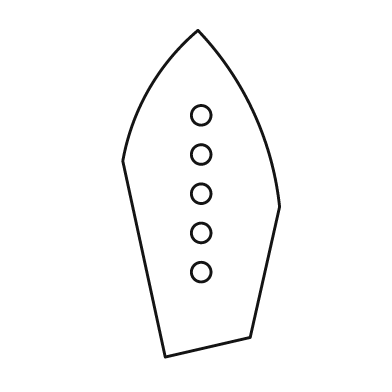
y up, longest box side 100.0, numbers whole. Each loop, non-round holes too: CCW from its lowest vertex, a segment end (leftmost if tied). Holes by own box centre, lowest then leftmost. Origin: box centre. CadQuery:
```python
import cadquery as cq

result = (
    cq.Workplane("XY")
    .moveTo(-11.0, -50.0)
    .lineTo(15.0, -44.0)
    .lineTo(24.0, -4.0)
    .threePointArc((16.0, 25.0), (-1.0, 50.0))
    .threePointArc((-16.0, 32.0), (-24.0, 10.0))
    .close()
    .moveTo(0.0, -24.0)
    .circle(3.0)
    .moveTo(0.0, -12.0)
    .circle(3.0)
    .moveTo(0.0, 0.0)
    .circle(3.0)
    .moveTo(0.0, 12.0)
    .circle(3.0)
    .moveTo(0.0, 24.0)
    .circle(3.0)
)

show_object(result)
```